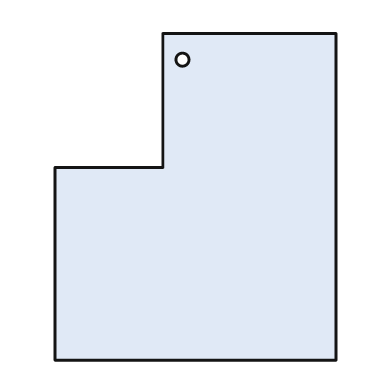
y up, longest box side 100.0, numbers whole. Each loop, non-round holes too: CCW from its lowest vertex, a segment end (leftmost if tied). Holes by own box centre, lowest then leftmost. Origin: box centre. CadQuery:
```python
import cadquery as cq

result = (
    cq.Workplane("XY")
    .moveTo(-43.0, -50.0)
    .lineTo(43.0, -50.0)
    .lineTo(43.0, 50.0)
    .lineTo(-10.0, 50.0)
    .lineTo(-10.0, 9.0)
    .lineTo(-43.0, 9.0)
    .close()
    .moveTo(-4.0, 42.0)
    .circle(2.0)
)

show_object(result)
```